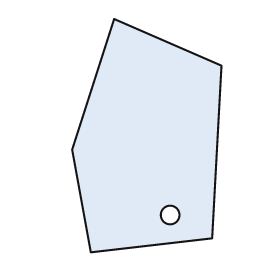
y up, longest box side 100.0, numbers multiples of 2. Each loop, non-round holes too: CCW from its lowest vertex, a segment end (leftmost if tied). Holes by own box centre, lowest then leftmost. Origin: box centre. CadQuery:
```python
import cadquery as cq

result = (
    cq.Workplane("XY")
    .moveTo(-24.0, -50.0)
    .lineTo(28.0, -44.0)
    .lineTo(32.0, 30.0)
    .lineTo(-14.0, 50.0)
    .lineTo(-32.0, -6.0)
    .close()
    .moveTo(10.0, -34.0)
    .circle(4.0)
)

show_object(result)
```